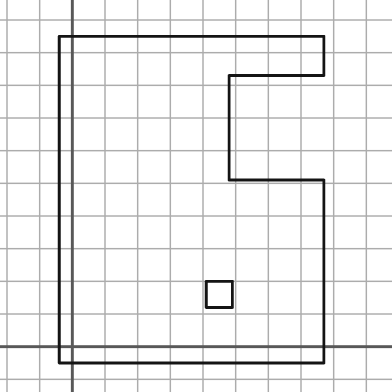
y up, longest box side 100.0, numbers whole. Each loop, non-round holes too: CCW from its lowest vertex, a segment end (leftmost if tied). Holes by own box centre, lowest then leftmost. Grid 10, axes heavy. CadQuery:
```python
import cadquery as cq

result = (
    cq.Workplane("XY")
    .moveTo(-4.0, -5.0)
    .lineTo(77.0, -5.0)
    .lineTo(77.0, 51.0)
    .lineTo(48.0, 51.0)
    .lineTo(48.0, 83.0)
    .lineTo(77.0, 83.0)
    .lineTo(77.0, 95.0)
    .lineTo(-4.0, 95.0)
    .close()
    .moveTo(41.0, 12.0)
    .lineTo(49.0, 12.0)
    .lineTo(49.0, 20.0)
    .lineTo(41.0, 20.0)
    .close()
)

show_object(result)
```